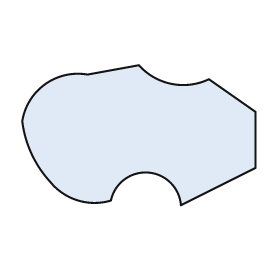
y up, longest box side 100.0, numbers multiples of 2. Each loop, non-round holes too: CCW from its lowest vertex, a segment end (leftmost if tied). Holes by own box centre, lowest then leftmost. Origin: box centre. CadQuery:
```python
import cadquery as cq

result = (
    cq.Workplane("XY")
    .moveTo(18.0, -30.0)
    .lineTo(50.0, -14.0)
    .lineTo(50.0, 10.0)
    .lineTo(30.0, 24.0)
    .threePointArc((14.0, 22.0), (0.0, 30.0))
    .lineTo(-22.0, 26.0)
    .threePointArc((-40.0, 22.0), (-50.0, 6.0))
    .threePointArc((-46.0, -8.0), (-38.0, -20.0))
    .threePointArc((-26.0, -28.0), (-12.0, -28.0))
    .threePointArc((4.0, -16.0), (18.0, -30.0))
    .close()
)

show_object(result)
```